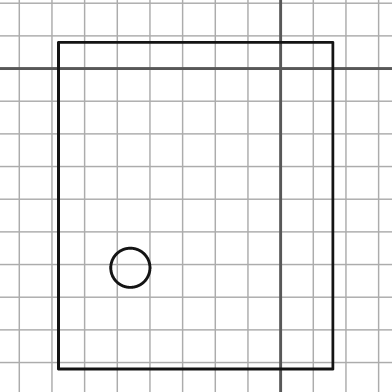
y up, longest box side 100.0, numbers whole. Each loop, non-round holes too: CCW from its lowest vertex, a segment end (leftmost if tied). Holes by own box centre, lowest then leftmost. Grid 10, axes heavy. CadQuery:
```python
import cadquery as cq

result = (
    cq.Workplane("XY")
    .moveTo(-68.0, -92.0)
    .lineTo(16.0, -92.0)
    .lineTo(16.0, 8.0)
    .lineTo(-68.0, 8.0)
    .close()
    .moveTo(-46.0, -61.0)
    .circle(6.0)
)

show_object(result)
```